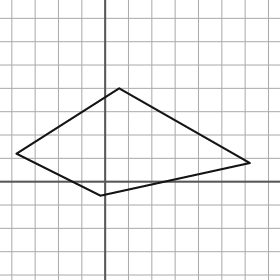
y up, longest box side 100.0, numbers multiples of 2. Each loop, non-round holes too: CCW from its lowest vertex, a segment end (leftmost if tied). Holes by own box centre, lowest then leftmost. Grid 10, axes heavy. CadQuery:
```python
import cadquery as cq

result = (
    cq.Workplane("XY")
    .moveTo(-2.0, -6.0)
    .lineTo(62.0, 8.0)
    .lineTo(6.0, 40.0)
    .lineTo(-38.0, 12.0)
    .close()
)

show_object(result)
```